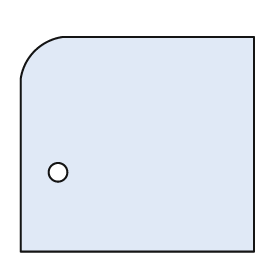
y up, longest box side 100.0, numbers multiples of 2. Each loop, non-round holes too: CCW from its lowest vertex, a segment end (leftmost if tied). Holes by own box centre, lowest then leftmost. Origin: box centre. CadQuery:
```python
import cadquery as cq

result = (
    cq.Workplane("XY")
    .moveTo(-50.0, -46.0)
    .lineTo(50.0, -46.0)
    .lineTo(50.0, 46.0)
    .lineTo(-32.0, 46.0)
    .threePointArc((-44.0, 40.0), (-50.0, 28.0))
    .close()
    .moveTo(-34.0, -12.0)
    .circle(4.0)
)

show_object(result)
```